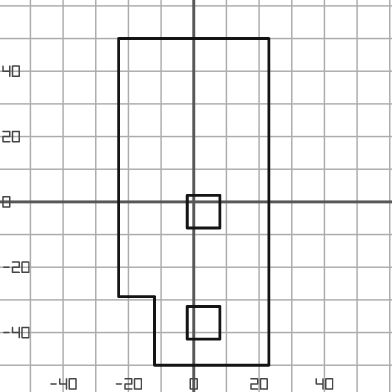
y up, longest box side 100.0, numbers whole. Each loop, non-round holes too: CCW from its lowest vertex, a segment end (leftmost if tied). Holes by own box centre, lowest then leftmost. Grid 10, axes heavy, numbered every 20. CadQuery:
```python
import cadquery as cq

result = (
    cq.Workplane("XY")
    .moveTo(-12.0, -50.0)
    .lineTo(23.0, -50.0)
    .lineTo(23.0, 50.0)
    .lineTo(-23.0, 50.0)
    .lineTo(-23.0, -29.0)
    .lineTo(-12.0, -29.0)
    .close()
    .moveTo(-2.0, -42.0)
    .lineTo(8.0, -42.0)
    .lineTo(8.0, -32.0)
    .lineTo(-2.0, -32.0)
    .close()
    .moveTo(-2.0, -8.0)
    .lineTo(8.0, -8.0)
    .lineTo(8.0, 2.0)
    .lineTo(-2.0, 2.0)
    .close()
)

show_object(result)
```